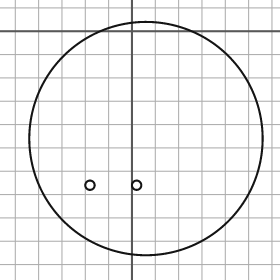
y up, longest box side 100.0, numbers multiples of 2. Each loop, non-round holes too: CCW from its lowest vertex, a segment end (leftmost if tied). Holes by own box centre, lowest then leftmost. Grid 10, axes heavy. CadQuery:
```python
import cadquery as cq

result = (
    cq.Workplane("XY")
    .moveTo(6.0, -46.0)
    .circle(50.0)
    .moveTo(-18.0, -66.0)
    .circle(2.0)
    .moveTo(2.0, -66.0)
    .circle(2.0)
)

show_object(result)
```